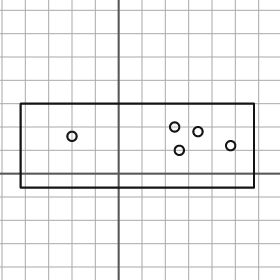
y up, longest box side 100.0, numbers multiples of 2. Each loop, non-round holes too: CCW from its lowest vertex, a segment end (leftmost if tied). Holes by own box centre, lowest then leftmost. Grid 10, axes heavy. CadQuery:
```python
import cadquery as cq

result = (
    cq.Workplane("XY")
    .moveTo(-42.0, -6.0)
    .lineTo(58.0, -6.0)
    .lineTo(58.0, 30.0)
    .lineTo(-42.0, 30.0)
    .close()
    .moveTo(26.0, 10.0)
    .circle(2.0)
    .moveTo(48.0, 12.0)
    .circle(2.0)
    .moveTo(-20.0, 16.0)
    .circle(2.0)
    .moveTo(34.0, 18.0)
    .circle(2.0)
    .moveTo(24.0, 20.0)
    .circle(2.0)
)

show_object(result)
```